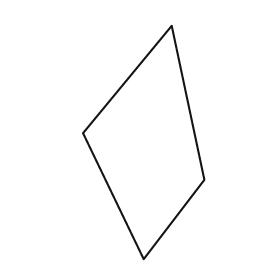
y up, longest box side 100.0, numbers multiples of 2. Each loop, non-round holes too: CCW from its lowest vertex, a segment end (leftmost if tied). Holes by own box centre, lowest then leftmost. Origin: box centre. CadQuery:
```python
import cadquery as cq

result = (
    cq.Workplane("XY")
    .moveTo(0.0, -50.0)
    .lineTo(26.0, -16.0)
    .lineTo(12.0, 50.0)
    .lineTo(-26.0, 4.0)
    .close()
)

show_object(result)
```